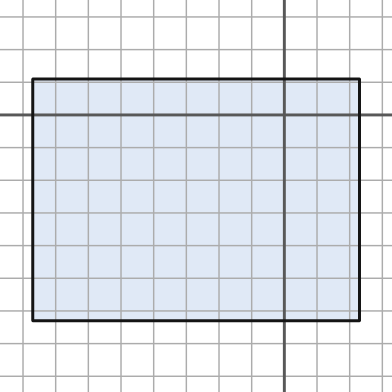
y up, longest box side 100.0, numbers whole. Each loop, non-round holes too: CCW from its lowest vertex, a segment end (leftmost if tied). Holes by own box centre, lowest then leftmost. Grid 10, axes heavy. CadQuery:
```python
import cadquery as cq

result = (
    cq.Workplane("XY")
    .moveTo(-77.0, -63.0)
    .lineTo(23.0, -63.0)
    .lineTo(23.0, 11.0)
    .lineTo(-77.0, 11.0)
    .close()
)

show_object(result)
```